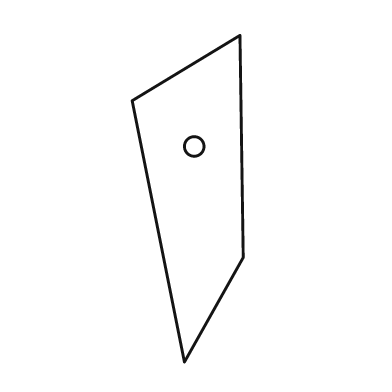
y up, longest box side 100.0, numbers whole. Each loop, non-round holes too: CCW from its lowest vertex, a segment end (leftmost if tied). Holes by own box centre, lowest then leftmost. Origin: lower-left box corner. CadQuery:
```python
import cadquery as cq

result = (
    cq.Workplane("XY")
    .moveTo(16.0, 0.0)
    .lineTo(34.0, 32.0)
    .lineTo(33.0, 100.0)
    .lineTo(0.0, 80.0)
    .close()
    .moveTo(19.0, 66.0)
    .circle(3.0)
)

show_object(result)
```